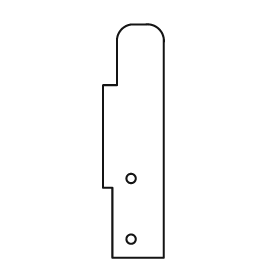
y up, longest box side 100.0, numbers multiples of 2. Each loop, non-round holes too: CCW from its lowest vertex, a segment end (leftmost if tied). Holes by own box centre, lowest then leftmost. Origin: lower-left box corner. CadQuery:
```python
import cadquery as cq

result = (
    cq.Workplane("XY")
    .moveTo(4.0, 0.0)
    .lineTo(26.0, 0.0)
    .lineTo(26.0, 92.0)
    .threePointArc((24.0, 98.0), (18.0, 100.0))
    .lineTo(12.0, 100.0)
    .threePointArc((8.0, 98.0), (6.0, 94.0))
    .lineTo(6.0, 74.0)
    .lineTo(0.0, 74.0)
    .lineTo(0.0, 30.0)
    .lineTo(4.0, 30.0)
    .close()
    .moveTo(12.0, 8.0)
    .circle(2.0)
    .moveTo(12.0, 34.0)
    .circle(2.0)
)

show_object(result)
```